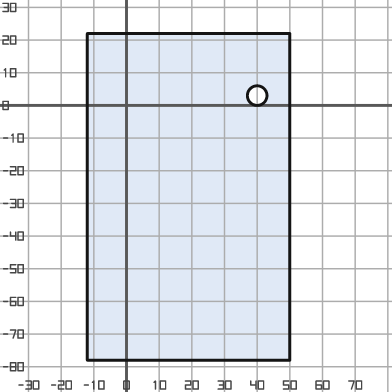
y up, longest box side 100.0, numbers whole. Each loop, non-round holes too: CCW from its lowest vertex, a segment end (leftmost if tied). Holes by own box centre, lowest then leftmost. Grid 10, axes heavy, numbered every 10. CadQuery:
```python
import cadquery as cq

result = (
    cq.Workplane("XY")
    .moveTo(-12.0, -78.0)
    .lineTo(50.0, -78.0)
    .lineTo(50.0, 22.0)
    .lineTo(-12.0, 22.0)
    .close()
    .moveTo(40.0, 3.0)
    .circle(3.0)
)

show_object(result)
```